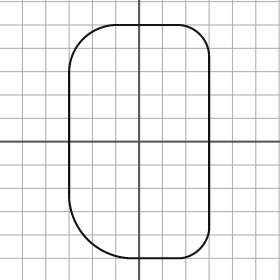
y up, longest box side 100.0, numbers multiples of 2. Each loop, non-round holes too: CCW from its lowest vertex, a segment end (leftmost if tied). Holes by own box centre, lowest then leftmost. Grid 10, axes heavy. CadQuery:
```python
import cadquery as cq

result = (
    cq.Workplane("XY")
    .moveTo(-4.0, -50.0)
    .lineTo(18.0, -50.0)
    .threePointArc((26.0, -46.0), (30.0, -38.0))
    .lineTo(30.0, 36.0)
    .threePointArc((26.0, 46.0), (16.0, 50.0))
    .lineTo(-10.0, 50.0)
    .threePointArc((-24.0, 44.0), (-30.0, 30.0))
    .lineTo(-30.0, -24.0)
    .threePointArc((-22.0, -42.0), (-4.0, -50.0))
    .close()
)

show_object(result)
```